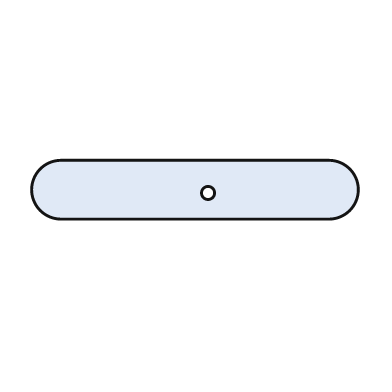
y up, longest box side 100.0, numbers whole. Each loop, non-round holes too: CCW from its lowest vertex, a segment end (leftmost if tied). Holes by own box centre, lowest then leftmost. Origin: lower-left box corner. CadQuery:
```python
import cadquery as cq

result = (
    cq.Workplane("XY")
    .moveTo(9.0, 0.0)
    .lineTo(91.0, 0.0)
    .threePointArc((100.0, 9.0), (91.0, 18.0))
    .lineTo(9.0, 18.0)
    .threePointArc((0.0, 9.0), (9.0, 0.0))
    .close()
    .moveTo(54.0, 8.0)
    .circle(2.0)
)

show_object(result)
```